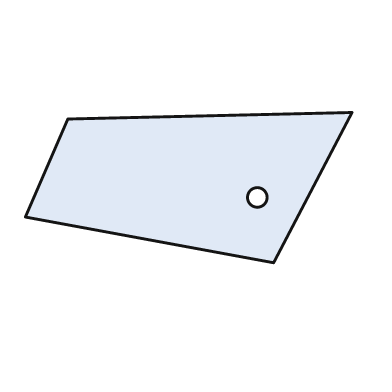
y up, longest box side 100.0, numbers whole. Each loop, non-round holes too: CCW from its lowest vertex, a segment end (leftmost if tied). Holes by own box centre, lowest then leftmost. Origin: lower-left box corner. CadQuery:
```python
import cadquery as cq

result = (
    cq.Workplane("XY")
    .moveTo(76.0, 0.0)
    .lineTo(100.0, 46.0)
    .lineTo(13.0, 44.0)
    .lineTo(0.0, 14.0)
    .close()
    .moveTo(71.0, 20.0)
    .circle(3.0)
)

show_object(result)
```